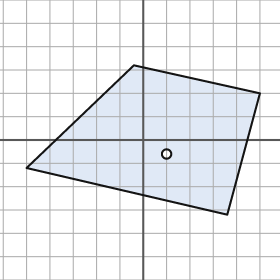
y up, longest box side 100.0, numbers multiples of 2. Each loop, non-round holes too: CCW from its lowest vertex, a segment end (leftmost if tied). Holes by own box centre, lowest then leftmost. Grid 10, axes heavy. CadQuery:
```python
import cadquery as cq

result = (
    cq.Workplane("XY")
    .moveTo(36.0, -32.0)
    .lineTo(50.0, 20.0)
    .lineTo(-4.0, 32.0)
    .lineTo(-50.0, -12.0)
    .close()
    .moveTo(10.0, -6.0)
    .circle(2.0)
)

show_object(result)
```